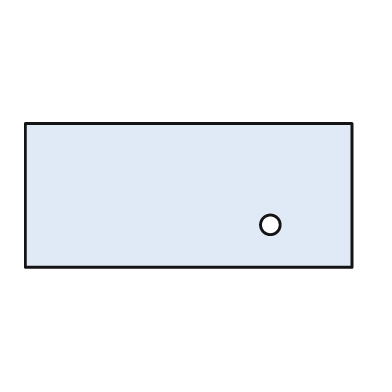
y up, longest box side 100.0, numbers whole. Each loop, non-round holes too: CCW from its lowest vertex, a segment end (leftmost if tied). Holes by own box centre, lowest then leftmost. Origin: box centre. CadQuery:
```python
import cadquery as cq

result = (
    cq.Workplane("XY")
    .moveTo(-50.0, -22.0)
    .lineTo(50.0, -22.0)
    .lineTo(50.0, 22.0)
    .lineTo(-50.0, 22.0)
    .close()
    .moveTo(25.0, -9.0)
    .circle(3.0)
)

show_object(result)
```